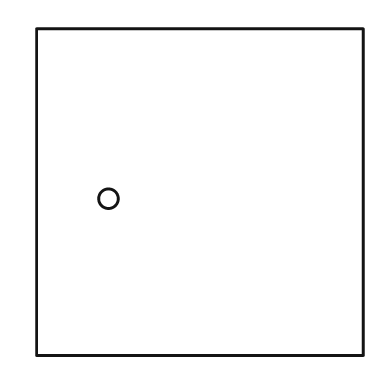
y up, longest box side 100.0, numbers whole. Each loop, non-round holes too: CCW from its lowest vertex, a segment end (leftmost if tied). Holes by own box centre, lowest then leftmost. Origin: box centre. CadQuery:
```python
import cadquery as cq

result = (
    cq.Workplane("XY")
    .moveTo(-50.0, -50.0)
    .lineTo(50.0, -50.0)
    .lineTo(50.0, 50.0)
    .lineTo(-50.0, 50.0)
    .close()
    .moveTo(-28.0, -2.0)
    .circle(3.0)
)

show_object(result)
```